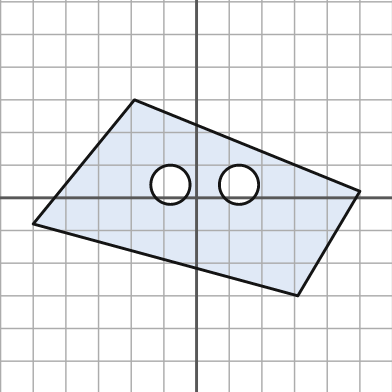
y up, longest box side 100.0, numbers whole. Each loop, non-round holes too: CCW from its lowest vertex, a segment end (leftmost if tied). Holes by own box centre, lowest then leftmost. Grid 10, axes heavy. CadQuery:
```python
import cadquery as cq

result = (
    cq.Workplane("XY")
    .moveTo(31.0, -30.0)
    .lineTo(50.0, 2.0)
    .lineTo(-19.0, 30.0)
    .lineTo(-50.0, -8.0)
    .close()
    .moveTo(-8.0, 4.0)
    .circle(6.0)
    .moveTo(13.0, 4.0)
    .circle(6.0)
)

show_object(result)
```